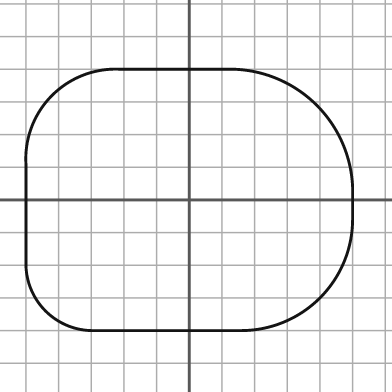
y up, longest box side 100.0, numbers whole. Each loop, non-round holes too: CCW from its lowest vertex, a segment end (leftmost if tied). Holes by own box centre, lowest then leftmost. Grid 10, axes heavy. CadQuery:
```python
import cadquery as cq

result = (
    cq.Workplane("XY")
    .moveTo(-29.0, -40.0)
    .lineTo(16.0, -40.0)
    .threePointArc((40.0, -30.0), (50.0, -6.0))
    .lineTo(50.0, 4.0)
    .threePointArc((39.0, 29.0), (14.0, 40.0))
    .lineTo(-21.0, 40.0)
    .threePointArc((-42.0, 32.0), (-50.0, 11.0))
    .lineTo(-50.0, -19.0)
    .threePointArc((-44.0, -34.0), (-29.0, -40.0))
    .close()
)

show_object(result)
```